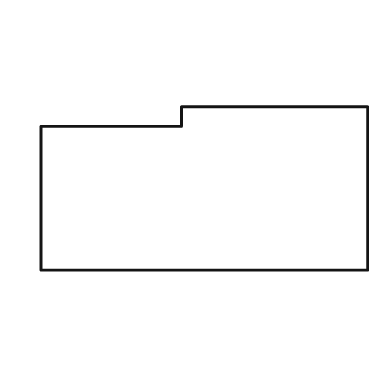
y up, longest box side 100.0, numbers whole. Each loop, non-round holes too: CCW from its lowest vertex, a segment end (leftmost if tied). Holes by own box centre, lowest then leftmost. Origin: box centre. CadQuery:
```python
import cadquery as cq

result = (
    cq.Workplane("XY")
    .moveTo(-50.0, -25.0)
    .lineTo(50.0, -25.0)
    .lineTo(50.0, 25.0)
    .lineTo(-7.0, 25.0)
    .lineTo(-7.0, 19.0)
    .lineTo(-50.0, 19.0)
    .close()
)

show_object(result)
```